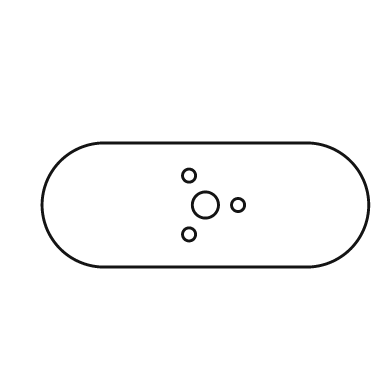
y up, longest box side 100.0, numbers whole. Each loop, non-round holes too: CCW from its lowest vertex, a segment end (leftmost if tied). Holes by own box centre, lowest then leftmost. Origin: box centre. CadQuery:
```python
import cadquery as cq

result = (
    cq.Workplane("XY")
    .moveTo(-31.0, -19.0)
    .lineTo(31.0, -19.0)
    .threePointArc((50.0, 0.0), (31.0, 19.0))
    .lineTo(-31.0, 19.0)
    .threePointArc((-50.0, 0.0), (-31.0, -19.0))
    .close()
    .moveTo(-5.0, -9.0)
    .circle(2.0)
    .moveTo(0.0, 0.0)
    .circle(4.0)
    .moveTo(10.0, 0.0)
    .circle(2.0)
    .moveTo(-5.0, 9.0)
    .circle(2.0)
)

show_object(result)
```